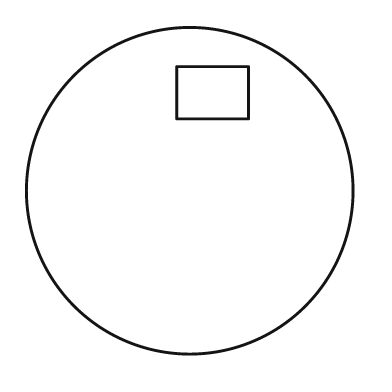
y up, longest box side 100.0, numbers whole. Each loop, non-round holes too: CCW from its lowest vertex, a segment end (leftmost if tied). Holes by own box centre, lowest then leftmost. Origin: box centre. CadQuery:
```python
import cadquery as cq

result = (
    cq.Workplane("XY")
    .moveTo(0.0, 0.0)
    .circle(50.0)
    .moveTo(-4.0, 22.0)
    .lineTo(18.0, 22.0)
    .lineTo(18.0, 38.0)
    .lineTo(-4.0, 38.0)
    .close()
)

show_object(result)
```